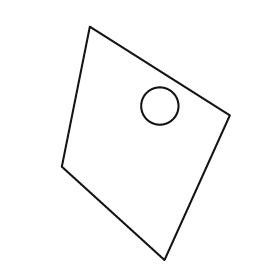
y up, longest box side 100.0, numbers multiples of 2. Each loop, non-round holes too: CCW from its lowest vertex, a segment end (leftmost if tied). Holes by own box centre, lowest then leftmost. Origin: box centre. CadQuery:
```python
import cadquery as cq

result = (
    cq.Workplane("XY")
    .moveTo(8.0, -50.0)
    .lineTo(36.0, 12.0)
    .lineTo(-24.0, 50.0)
    .lineTo(-36.0, -10.0)
    .close()
    .moveTo(6.0, 16.0)
    .circle(8.0)
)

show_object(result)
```